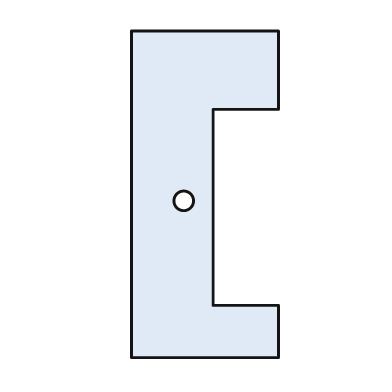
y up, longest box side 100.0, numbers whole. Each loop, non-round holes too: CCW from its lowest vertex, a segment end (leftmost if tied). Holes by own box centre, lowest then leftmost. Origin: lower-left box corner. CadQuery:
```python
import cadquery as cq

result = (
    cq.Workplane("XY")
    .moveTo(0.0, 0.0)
    .lineTo(45.0, 0.0)
    .lineTo(45.0, 16.0)
    .lineTo(25.0, 16.0)
    .lineTo(25.0, 76.0)
    .lineTo(45.0, 76.0)
    .lineTo(45.0, 100.0)
    .lineTo(0.0, 100.0)
    .close()
    .moveTo(16.0, 48.0)
    .circle(3.0)
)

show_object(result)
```